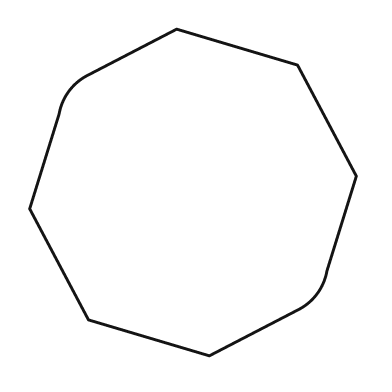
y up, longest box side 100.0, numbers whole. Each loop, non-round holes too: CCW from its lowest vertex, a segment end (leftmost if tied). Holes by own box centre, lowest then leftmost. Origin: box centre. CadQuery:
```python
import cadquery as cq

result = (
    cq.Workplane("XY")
    .moveTo(5.0, -50.0)
    .lineTo(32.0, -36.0)
    .threePointArc((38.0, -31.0), (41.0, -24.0))
    .lineTo(50.0, 5.0)
    .lineTo(32.0, 39.0)
    .lineTo(-5.0, 50.0)
    .lineTo(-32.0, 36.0)
    .threePointArc((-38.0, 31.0), (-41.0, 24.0))
    .lineTo(-50.0, -5.0)
    .lineTo(-32.0, -39.0)
    .close()
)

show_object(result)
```